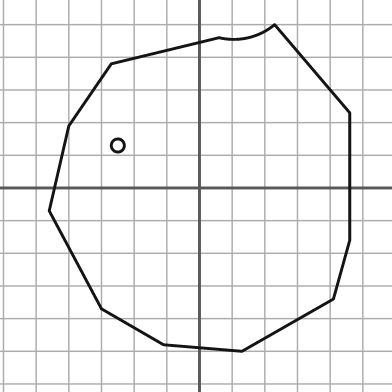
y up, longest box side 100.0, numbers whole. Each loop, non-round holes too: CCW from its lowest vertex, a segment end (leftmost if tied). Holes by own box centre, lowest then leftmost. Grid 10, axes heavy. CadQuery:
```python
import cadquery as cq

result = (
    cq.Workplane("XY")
    .moveTo(13.0, -50.0)
    .lineTo(41.0, -34.0)
    .lineTo(46.0, -16.0)
    .lineTo(46.0, 23.0)
    .lineTo(23.0, 50.0)
    .threePointArc((15.0, 46.0), (6.0, 46.0))
    .lineTo(-27.0, 38.0)
    .lineTo(-40.0, 19.0)
    .lineTo(-46.0, -7.0)
    .lineTo(-30.0, -37.0)
    .lineTo(-11.0, -48.0)
    .close()
    .moveTo(-25.0, 13.0)
    .circle(2.0)
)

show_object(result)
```